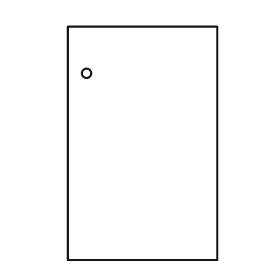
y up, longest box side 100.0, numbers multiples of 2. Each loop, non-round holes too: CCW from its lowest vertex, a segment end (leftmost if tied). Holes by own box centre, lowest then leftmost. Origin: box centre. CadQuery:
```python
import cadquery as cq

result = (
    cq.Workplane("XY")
    .moveTo(-32.0, -50.0)
    .lineTo(32.0, -50.0)
    .lineTo(32.0, 50.0)
    .lineTo(-32.0, 50.0)
    .close()
    .moveTo(-24.0, 30.0)
    .circle(2.0)
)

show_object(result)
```